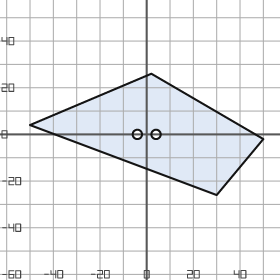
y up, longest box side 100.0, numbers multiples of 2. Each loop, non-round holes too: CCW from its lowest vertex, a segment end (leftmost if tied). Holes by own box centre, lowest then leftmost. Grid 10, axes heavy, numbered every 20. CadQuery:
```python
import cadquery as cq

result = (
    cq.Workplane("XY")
    .moveTo(30.0, -26.0)
    .lineTo(50.0, -2.0)
    .lineTo(2.0, 26.0)
    .lineTo(-50.0, 4.0)
    .close()
    .moveTo(-4.0, 0.0)
    .circle(2.0)
    .moveTo(4.0, 0.0)
    .circle(2.0)
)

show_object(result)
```